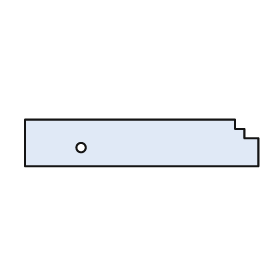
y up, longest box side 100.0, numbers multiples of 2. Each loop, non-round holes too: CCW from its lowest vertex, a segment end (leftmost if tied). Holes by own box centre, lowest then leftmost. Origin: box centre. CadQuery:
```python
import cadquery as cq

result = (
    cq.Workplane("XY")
    .moveTo(-50.0, -10.0)
    .lineTo(50.0, -10.0)
    .lineTo(50.0, 2.0)
    .lineTo(44.0, 2.0)
    .lineTo(44.0, 6.0)
    .lineTo(40.0, 6.0)
    .lineTo(40.0, 10.0)
    .lineTo(-50.0, 10.0)
    .close()
    .moveTo(-26.0, -2.0)
    .circle(2.0)
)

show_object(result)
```